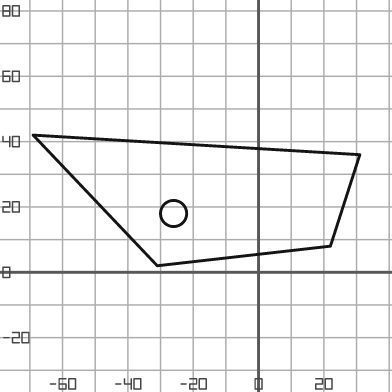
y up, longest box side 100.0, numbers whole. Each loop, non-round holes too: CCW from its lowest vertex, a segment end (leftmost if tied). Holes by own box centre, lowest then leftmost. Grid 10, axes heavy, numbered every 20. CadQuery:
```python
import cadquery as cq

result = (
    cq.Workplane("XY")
    .moveTo(-31.0, 2.0)
    .lineTo(22.0, 8.0)
    .lineTo(31.0, 36.0)
    .lineTo(-69.0, 42.0)
    .close()
    .moveTo(-26.0, 18.0)
    .circle(4.0)
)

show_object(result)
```